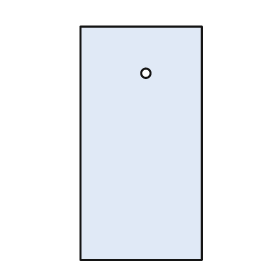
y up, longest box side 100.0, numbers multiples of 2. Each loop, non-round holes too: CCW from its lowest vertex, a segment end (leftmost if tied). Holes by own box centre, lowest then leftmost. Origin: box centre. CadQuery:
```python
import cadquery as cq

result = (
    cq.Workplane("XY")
    .moveTo(-26.0, -50.0)
    .lineTo(26.0, -50.0)
    .lineTo(26.0, 50.0)
    .lineTo(-26.0, 50.0)
    .close()
    .moveTo(2.0, 30.0)
    .circle(2.0)
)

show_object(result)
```